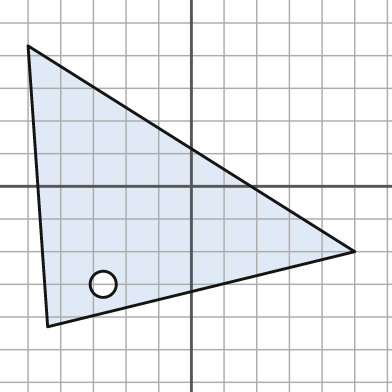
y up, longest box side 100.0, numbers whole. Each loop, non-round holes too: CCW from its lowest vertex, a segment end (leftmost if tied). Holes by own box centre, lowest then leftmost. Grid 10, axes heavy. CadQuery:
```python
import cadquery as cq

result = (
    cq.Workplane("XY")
    .moveTo(-44.0, -43.0)
    .lineTo(50.0, -20.0)
    .lineTo(-50.0, 43.0)
    .close()
    .moveTo(-27.0, -30.0)
    .circle(4.0)
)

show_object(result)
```